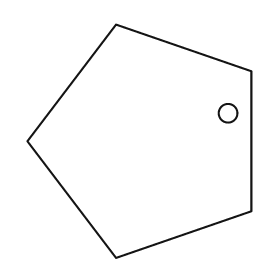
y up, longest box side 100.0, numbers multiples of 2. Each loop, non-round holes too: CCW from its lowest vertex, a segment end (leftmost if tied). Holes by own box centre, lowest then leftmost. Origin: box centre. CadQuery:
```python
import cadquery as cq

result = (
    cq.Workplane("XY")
    .moveTo(-10.0, -50.0)
    .lineTo(48.0, -30.0)
    .lineTo(48.0, 30.0)
    .lineTo(-10.0, 50.0)
    .lineTo(-48.0, 0.0)
    .close()
    .moveTo(38.0, 12.0)
    .circle(4.0)
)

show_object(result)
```